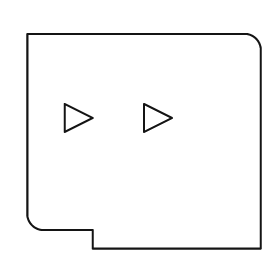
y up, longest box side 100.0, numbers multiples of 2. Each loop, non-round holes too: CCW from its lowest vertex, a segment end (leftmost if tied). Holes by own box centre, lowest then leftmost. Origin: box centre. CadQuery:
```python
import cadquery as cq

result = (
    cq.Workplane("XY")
    .moveTo(-22.0, -46.0)
    .lineTo(50.0, -46.0)
    .lineTo(50.0, 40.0)
    .threePointArc((48.0, 44.0), (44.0, 46.0))
    .lineTo(-50.0, 46.0)
    .lineTo(-50.0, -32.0)
    .threePointArc((-48.0, -36.0), (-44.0, -38.0))
    .lineTo(-22.0, -38.0)
    .close()
    .moveTo(-34.0, 4.0)
    .lineTo(-22.0, 10.0)
    .lineTo(-34.0, 16.0)
    .close()
    .moveTo(0.0, 4.0)
    .lineTo(12.0, 10.0)
    .lineTo(0.0, 16.0)
    .close()
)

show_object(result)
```